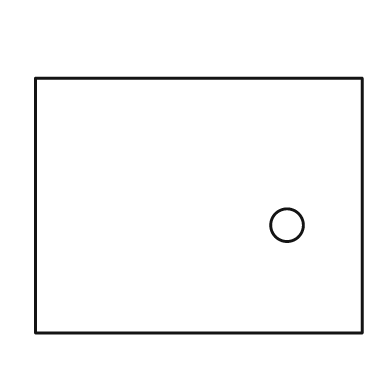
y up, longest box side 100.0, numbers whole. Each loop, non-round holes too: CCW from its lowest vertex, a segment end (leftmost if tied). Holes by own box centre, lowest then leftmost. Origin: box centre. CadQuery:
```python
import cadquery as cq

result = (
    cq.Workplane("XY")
    .moveTo(-50.0, -39.0)
    .lineTo(50.0, -39.0)
    .lineTo(50.0, 39.0)
    .lineTo(-50.0, 39.0)
    .close()
    .moveTo(27.0, -6.0)
    .circle(5.0)
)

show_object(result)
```